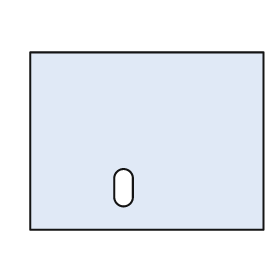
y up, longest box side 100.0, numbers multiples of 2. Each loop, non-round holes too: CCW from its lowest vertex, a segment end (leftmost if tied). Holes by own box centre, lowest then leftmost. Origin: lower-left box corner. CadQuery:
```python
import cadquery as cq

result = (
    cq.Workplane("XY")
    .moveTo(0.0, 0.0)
    .lineTo(100.0, 0.0)
    .lineTo(100.0, 76.0)
    .lineTo(0.0, 76.0)
    .close()
    .moveTo(36.0, 14.0)
    .threePointArc((40.0, 10.0), (44.0, 14.0))
    .lineTo(44.0, 22.0)
    .threePointArc((40.0, 26.0), (36.0, 22.0))
    .close()
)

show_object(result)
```